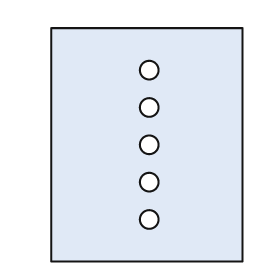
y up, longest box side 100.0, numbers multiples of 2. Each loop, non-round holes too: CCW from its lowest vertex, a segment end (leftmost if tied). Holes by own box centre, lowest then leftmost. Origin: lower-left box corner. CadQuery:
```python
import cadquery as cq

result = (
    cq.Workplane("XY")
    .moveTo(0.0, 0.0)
    .lineTo(82.0, 0.0)
    .lineTo(82.0, 100.0)
    .lineTo(0.0, 100.0)
    .close()
    .moveTo(42.0, 18.0)
    .circle(4.0)
    .moveTo(42.0, 34.0)
    .circle(4.0)
    .moveTo(42.0, 50.0)
    .circle(4.0)
    .moveTo(42.0, 66.0)
    .circle(4.0)
    .moveTo(42.0, 82.0)
    .circle(4.0)
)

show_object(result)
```